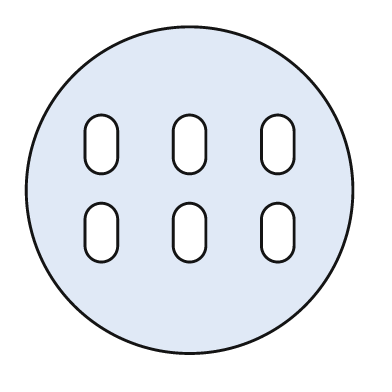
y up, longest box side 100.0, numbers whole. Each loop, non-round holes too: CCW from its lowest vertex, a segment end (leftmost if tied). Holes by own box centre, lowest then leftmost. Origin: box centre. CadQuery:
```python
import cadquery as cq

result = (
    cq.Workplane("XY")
    .moveTo(0.0, 0.0)
    .circle(50.0)
    .moveTo(-32.0, -17.0)
    .threePointArc((-27.0, -22.0), (-22.0, -17.0))
    .lineTo(-22.0, -9.0)
    .threePointArc((-27.0, -4.0), (-32.0, -9.0))
    .close()
    .moveTo(-5.0, -17.0)
    .threePointArc((0.0, -22.0), (5.0, -17.0))
    .lineTo(5.0, -9.0)
    .threePointArc((0.0, -4.0), (-5.0, -9.0))
    .close()
    .moveTo(22.0, -17.0)
    .threePointArc((27.0, -22.0), (32.0, -17.0))
    .lineTo(32.0, -9.0)
    .threePointArc((27.0, -4.0), (22.0, -9.0))
    .close()
    .moveTo(-32.0, 10.0)
    .threePointArc((-27.0, 5.0), (-22.0, 10.0))
    .lineTo(-22.0, 18.0)
    .threePointArc((-27.0, 23.0), (-32.0, 18.0))
    .close()
    .moveTo(-5.0, 10.0)
    .threePointArc((0.0, 5.0), (5.0, 10.0))
    .lineTo(5.0, 18.0)
    .threePointArc((0.0, 23.0), (-5.0, 18.0))
    .close()
    .moveTo(22.0, 10.0)
    .threePointArc((27.0, 5.0), (32.0, 10.0))
    .lineTo(32.0, 18.0)
    .threePointArc((27.0, 23.0), (22.0, 18.0))
    .close()
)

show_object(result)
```